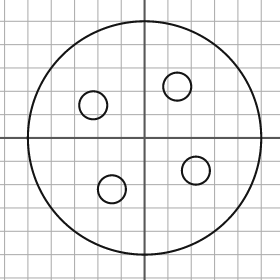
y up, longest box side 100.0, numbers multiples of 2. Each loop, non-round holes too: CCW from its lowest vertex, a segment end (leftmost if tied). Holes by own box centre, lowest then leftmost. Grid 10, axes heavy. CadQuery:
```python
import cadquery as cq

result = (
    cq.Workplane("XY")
    .moveTo(0.0, 0.0)
    .circle(50.0)
    .moveTo(-14.0, -22.0)
    .circle(6.0)
    .moveTo(22.0, -14.0)
    .circle(6.0)
    .moveTo(-22.0, 14.0)
    .circle(6.0)
    .moveTo(14.0, 22.0)
    .circle(6.0)
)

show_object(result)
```